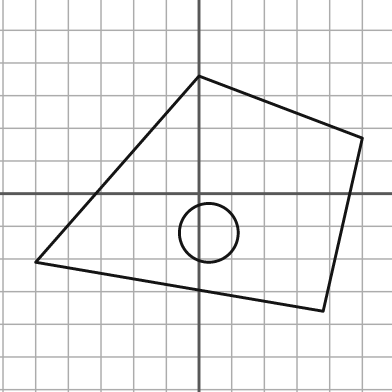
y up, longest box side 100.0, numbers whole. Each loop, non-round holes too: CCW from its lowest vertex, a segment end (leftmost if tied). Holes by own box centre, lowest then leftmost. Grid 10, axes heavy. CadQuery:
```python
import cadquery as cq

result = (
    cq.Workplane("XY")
    .moveTo(38.0, -36.0)
    .lineTo(50.0, 17.0)
    .lineTo(0.0, 36.0)
    .lineTo(-50.0, -21.0)
    .close()
    .moveTo(3.0, -12.0)
    .circle(9.0)
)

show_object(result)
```